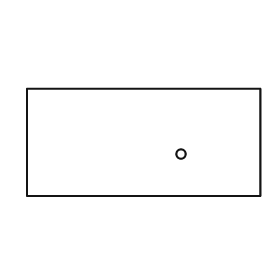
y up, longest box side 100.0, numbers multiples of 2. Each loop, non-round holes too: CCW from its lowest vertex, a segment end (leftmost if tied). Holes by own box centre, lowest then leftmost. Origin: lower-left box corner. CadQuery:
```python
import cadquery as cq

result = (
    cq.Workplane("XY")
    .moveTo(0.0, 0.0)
    .lineTo(100.0, 0.0)
    .lineTo(100.0, 46.0)
    .lineTo(0.0, 46.0)
    .close()
    .moveTo(66.0, 18.0)
    .circle(2.0)
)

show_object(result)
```